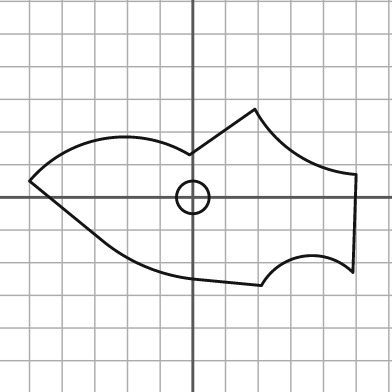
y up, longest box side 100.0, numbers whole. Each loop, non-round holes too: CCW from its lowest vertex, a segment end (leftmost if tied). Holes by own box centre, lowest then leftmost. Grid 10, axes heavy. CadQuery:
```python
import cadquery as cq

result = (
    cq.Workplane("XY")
    .moveTo(21.0, -27.0)
    .threePointArc((34.0, -18.0), (49.0, -23.0))
    .lineTo(50.0, 7.0)
    .threePointArc((32.0, 13.0), (19.0, 27.0))
    .lineTo(-1.0, 13.0)
    .threePointArc((-27.0, 18.0), (-50.0, 5.0))
    .lineTo(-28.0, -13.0)
    .threePointArc((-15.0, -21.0), (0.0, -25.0))
    .close()
    .moveTo(0.0, 0.0)
    .circle(5.0)
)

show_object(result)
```